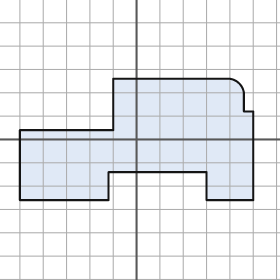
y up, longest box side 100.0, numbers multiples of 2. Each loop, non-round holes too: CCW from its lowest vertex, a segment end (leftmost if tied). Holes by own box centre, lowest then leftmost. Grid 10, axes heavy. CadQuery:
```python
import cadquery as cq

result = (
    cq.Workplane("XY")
    .moveTo(-50.0, -26.0)
    .lineTo(-12.0, -26.0)
    .lineTo(-12.0, -14.0)
    .lineTo(30.0, -14.0)
    .lineTo(30.0, -26.0)
    .lineTo(50.0, -26.0)
    .lineTo(50.0, 12.0)
    .lineTo(46.0, 12.0)
    .lineTo(46.0, 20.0)
    .threePointArc((44.0, 24.0), (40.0, 26.0))
    .lineTo(-10.0, 26.0)
    .lineTo(-10.0, 4.0)
    .lineTo(-50.0, 4.0)
    .close()
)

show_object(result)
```